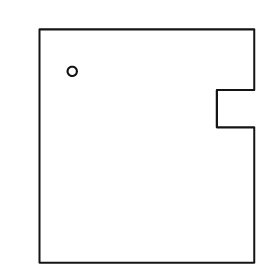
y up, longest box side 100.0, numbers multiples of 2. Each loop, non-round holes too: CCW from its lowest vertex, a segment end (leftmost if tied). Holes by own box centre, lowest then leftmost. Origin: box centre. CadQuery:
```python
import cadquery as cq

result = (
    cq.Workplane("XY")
    .moveTo(-46.0, -50.0)
    .lineTo(46.0, -50.0)
    .lineTo(46.0, 8.0)
    .lineTo(30.0, 8.0)
    .lineTo(30.0, 24.0)
    .lineTo(46.0, 24.0)
    .lineTo(46.0, 50.0)
    .lineTo(-46.0, 50.0)
    .close()
    .moveTo(-32.0, 32.0)
    .circle(2.0)
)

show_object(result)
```